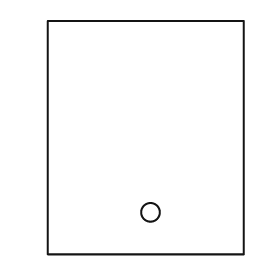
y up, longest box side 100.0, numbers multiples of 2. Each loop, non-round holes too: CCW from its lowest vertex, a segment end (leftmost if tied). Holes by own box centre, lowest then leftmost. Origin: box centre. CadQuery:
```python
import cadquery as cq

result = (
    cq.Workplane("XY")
    .moveTo(-42.0, -50.0)
    .lineTo(42.0, -50.0)
    .lineTo(42.0, 50.0)
    .lineTo(-42.0, 50.0)
    .close()
    .moveTo(2.0, -32.0)
    .circle(4.0)
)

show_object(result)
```